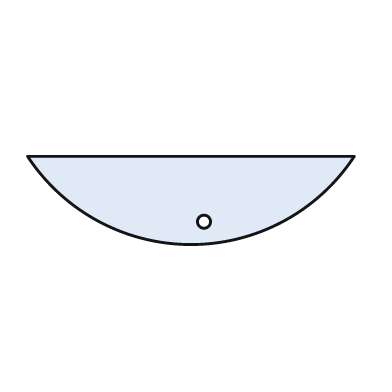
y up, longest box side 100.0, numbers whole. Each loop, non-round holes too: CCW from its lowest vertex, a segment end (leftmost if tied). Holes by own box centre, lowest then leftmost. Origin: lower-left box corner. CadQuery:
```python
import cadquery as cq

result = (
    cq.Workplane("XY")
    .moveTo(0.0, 27.0)
    .threePointArc((50.0, 0.0), (100.0, 27.0))
    .close()
    .moveTo(54.0, 7.0)
    .circle(2.0)
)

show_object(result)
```